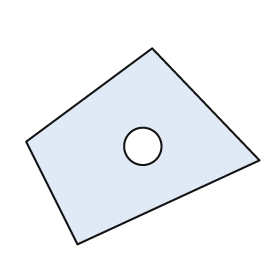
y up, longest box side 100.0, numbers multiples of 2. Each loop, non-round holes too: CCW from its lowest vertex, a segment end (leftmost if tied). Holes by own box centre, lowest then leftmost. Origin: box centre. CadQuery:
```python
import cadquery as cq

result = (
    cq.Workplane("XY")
    .moveTo(-28.0, -42.0)
    .lineTo(50.0, -6.0)
    .lineTo(4.0, 42.0)
    .lineTo(-50.0, 2.0)
    .close()
    .moveTo(0.0, 0.0)
    .circle(8.0)
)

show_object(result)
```